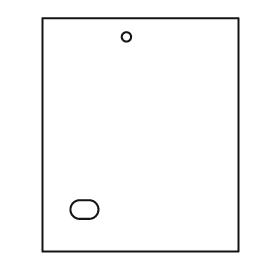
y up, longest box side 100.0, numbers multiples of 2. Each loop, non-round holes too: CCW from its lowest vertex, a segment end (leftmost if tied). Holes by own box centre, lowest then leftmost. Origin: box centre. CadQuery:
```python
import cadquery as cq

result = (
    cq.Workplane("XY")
    .moveTo(-42.0, -50.0)
    .lineTo(42.0, -50.0)
    .lineTo(42.0, 50.0)
    .lineTo(-42.0, 50.0)
    .close()
    .moveTo(-26.0, -36.0)
    .lineTo(-22.0, -36.0)
    .threePointArc((-18.0, -32.0), (-22.0, -28.0))
    .lineTo(-26.0, -28.0)
    .threePointArc((-30.0, -32.0), (-26.0, -36.0))
    .close()
    .moveTo(-6.0, 42.0)
    .circle(2.0)
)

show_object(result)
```